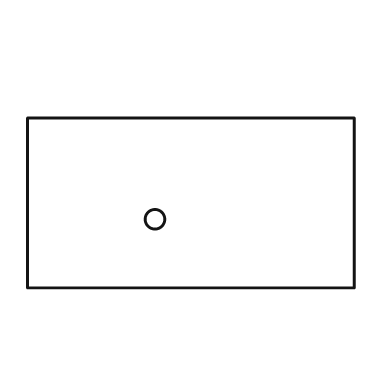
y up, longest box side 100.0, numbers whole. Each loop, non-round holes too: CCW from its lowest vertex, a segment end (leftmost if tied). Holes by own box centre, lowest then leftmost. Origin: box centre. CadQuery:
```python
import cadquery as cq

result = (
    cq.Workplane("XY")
    .moveTo(-50.0, -26.0)
    .lineTo(50.0, -26.0)
    .lineTo(50.0, 26.0)
    .lineTo(-50.0, 26.0)
    .close()
    .moveTo(-11.0, -5.0)
    .circle(3.0)
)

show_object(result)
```